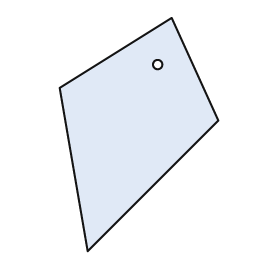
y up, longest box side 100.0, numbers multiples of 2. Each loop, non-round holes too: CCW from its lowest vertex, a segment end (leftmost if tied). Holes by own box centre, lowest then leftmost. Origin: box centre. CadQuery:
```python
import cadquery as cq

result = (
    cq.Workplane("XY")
    .moveTo(-22.0, -50.0)
    .lineTo(34.0, 6.0)
    .lineTo(14.0, 50.0)
    .lineTo(-34.0, 20.0)
    .close()
    .moveTo(8.0, 30.0)
    .circle(2.0)
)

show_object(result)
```